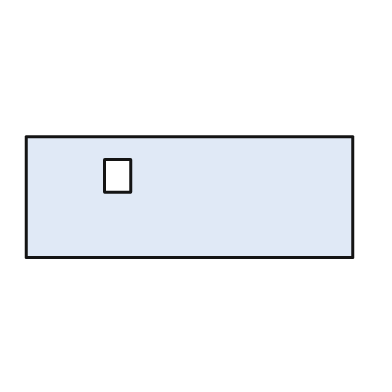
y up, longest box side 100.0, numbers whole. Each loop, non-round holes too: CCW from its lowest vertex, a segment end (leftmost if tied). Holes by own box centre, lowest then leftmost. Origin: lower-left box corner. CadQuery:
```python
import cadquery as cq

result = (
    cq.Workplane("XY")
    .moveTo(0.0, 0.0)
    .lineTo(100.0, 0.0)
    .lineTo(100.0, 37.0)
    .lineTo(0.0, 37.0)
    .close()
    .moveTo(24.0, 20.0)
    .lineTo(32.0, 20.0)
    .lineTo(32.0, 30.0)
    .lineTo(24.0, 30.0)
    .close()
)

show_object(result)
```